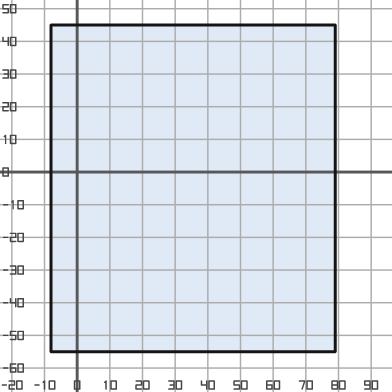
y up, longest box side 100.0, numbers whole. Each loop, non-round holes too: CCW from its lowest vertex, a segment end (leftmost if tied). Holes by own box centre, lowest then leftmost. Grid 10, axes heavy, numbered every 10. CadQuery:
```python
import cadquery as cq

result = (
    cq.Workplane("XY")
    .moveTo(-8.0, -55.0)
    .lineTo(79.0, -55.0)
    .lineTo(79.0, 45.0)
    .lineTo(-8.0, 45.0)
    .close()
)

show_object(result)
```